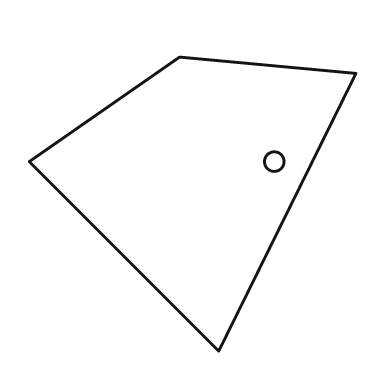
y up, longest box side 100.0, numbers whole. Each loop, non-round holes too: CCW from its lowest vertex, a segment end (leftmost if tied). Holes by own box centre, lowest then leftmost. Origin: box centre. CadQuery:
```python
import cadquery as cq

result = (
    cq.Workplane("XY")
    .moveTo(8.0, -45.0)
    .lineTo(50.0, 40.0)
    .lineTo(-4.0, 45.0)
    .lineTo(-50.0, 13.0)
    .close()
    .moveTo(25.0, 13.0)
    .circle(3.0)
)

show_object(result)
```